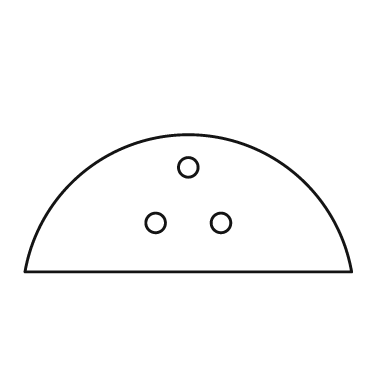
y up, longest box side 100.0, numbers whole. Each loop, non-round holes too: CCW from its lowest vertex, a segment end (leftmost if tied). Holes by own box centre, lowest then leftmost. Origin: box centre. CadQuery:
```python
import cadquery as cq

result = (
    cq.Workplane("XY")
    .moveTo(-50.0, -21.0)
    .lineTo(50.0, -21.0)
    .threePointArc((0.0, 21.0), (-50.0, -21.0))
    .close()
    .moveTo(-10.0, -6.0)
    .circle(3.0)
    .moveTo(10.0, -6.0)
    .circle(3.0)
    .moveTo(0.0, 11.0)
    .circle(3.0)
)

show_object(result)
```